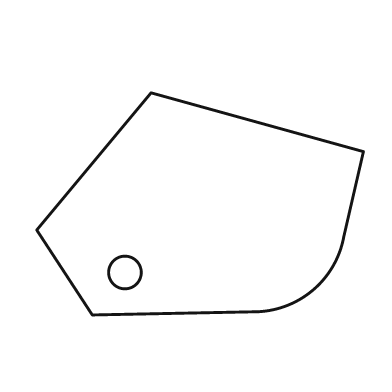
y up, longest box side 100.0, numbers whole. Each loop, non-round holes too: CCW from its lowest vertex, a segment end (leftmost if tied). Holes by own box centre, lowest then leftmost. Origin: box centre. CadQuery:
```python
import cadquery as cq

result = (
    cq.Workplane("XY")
    .moveTo(-33.0, -34.0)
    .lineTo(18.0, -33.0)
    .threePointArc((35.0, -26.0), (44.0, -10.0))
    .lineTo(50.0, 16.0)
    .lineTo(-15.0, 34.0)
    .lineTo(-50.0, -8.0)
    .close()
    .moveTo(-23.0, -21.0)
    .circle(5.0)
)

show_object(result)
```